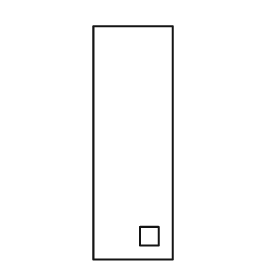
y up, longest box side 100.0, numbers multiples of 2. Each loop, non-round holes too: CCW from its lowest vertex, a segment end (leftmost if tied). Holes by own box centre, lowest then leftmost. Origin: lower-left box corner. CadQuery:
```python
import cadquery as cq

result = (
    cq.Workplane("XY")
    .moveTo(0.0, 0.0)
    .lineTo(34.0, 0.0)
    .lineTo(34.0, 100.0)
    .lineTo(0.0, 100.0)
    .close()
    .moveTo(20.0, 6.0)
    .lineTo(28.0, 6.0)
    .lineTo(28.0, 14.0)
    .lineTo(20.0, 14.0)
    .close()
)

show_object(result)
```